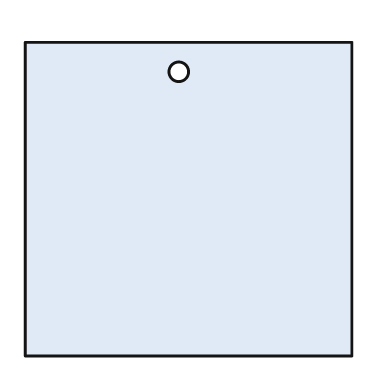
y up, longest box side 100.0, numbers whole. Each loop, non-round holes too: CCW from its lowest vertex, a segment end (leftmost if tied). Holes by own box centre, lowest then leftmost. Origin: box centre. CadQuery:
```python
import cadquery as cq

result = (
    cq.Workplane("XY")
    .moveTo(-50.0, -48.0)
    .lineTo(50.0, -48.0)
    .lineTo(50.0, 48.0)
    .lineTo(-50.0, 48.0)
    .close()
    .moveTo(-3.0, 39.0)
    .circle(3.0)
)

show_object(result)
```